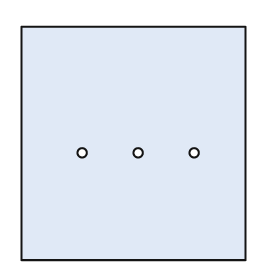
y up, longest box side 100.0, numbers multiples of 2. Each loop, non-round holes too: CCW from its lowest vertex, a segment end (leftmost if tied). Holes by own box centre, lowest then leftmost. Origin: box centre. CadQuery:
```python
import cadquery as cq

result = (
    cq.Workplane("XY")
    .moveTo(-48.0, -50.0)
    .lineTo(48.0, -50.0)
    .lineTo(48.0, 50.0)
    .lineTo(-48.0, 50.0)
    .close()
    .moveTo(-22.0, -4.0)
    .circle(2.0)
    .moveTo(2.0, -4.0)
    .circle(2.0)
    .moveTo(26.0, -4.0)
    .circle(2.0)
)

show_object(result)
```